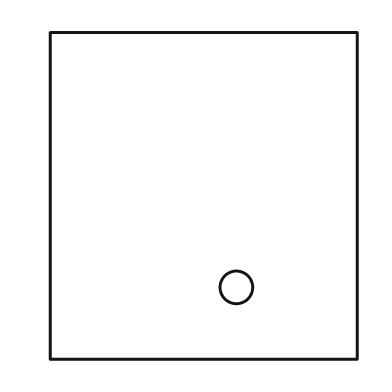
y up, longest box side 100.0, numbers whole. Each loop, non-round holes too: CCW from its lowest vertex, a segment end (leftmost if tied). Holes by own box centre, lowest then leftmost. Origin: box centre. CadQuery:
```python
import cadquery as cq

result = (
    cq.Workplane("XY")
    .moveTo(-47.0, -50.0)
    .lineTo(47.0, -50.0)
    .lineTo(47.0, 50.0)
    .lineTo(-47.0, 50.0)
    .close()
    .moveTo(10.0, -28.0)
    .circle(5.0)
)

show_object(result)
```